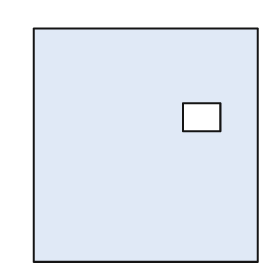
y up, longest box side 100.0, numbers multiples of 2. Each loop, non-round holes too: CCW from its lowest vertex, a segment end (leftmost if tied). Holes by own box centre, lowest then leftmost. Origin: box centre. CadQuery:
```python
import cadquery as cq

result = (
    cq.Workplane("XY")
    .moveTo(-48.0, -50.0)
    .lineTo(48.0, -50.0)
    .lineTo(48.0, 50.0)
    .lineTo(-48.0, 50.0)
    .close()
    .moveTo(16.0, 6.0)
    .lineTo(32.0, 6.0)
    .lineTo(32.0, 18.0)
    .lineTo(16.0, 18.0)
    .close()
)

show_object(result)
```